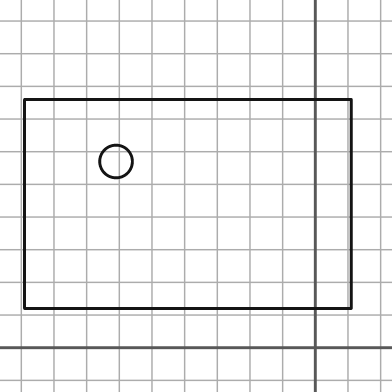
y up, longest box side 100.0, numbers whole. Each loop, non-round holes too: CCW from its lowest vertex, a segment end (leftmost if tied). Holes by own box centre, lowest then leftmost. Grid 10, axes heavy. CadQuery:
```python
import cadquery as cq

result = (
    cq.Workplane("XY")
    .moveTo(-89.0, 12.0)
    .lineTo(11.0, 12.0)
    .lineTo(11.0, 76.0)
    .lineTo(-89.0, 76.0)
    .close()
    .moveTo(-61.0, 57.0)
    .circle(5.0)
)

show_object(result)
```